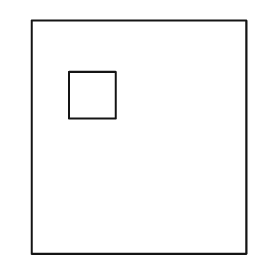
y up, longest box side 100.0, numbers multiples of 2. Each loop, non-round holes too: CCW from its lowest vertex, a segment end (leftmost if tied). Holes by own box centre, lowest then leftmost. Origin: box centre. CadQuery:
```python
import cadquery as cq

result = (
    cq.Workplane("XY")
    .moveTo(-46.0, -50.0)
    .lineTo(46.0, -50.0)
    .lineTo(46.0, 50.0)
    .lineTo(-46.0, 50.0)
    .close()
    .moveTo(-30.0, 8.0)
    .lineTo(-10.0, 8.0)
    .lineTo(-10.0, 28.0)
    .lineTo(-30.0, 28.0)
    .close()
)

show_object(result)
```